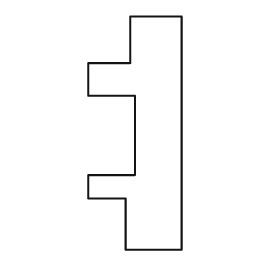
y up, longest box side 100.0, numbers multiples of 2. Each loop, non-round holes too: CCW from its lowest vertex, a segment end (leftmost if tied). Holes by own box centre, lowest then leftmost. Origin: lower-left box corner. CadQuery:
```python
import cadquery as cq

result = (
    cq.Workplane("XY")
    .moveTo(16.0, 0.0)
    .lineTo(40.0, 0.0)
    .lineTo(40.0, 100.0)
    .lineTo(18.0, 100.0)
    .lineTo(18.0, 80.0)
    .lineTo(0.0, 80.0)
    .lineTo(0.0, 66.0)
    .lineTo(20.0, 66.0)
    .lineTo(20.0, 32.0)
    .lineTo(0.0, 32.0)
    .lineTo(0.0, 22.0)
    .lineTo(16.0, 22.0)
    .close()
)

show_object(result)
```